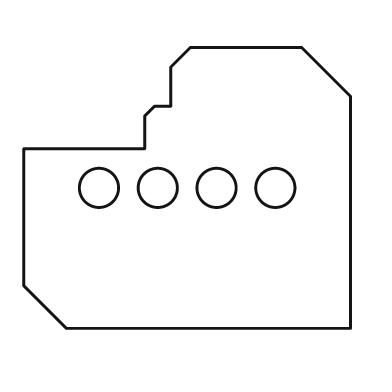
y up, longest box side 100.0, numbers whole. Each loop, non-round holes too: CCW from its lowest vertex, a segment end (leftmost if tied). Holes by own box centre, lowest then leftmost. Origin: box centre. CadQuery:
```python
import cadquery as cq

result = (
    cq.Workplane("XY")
    .moveTo(-37.0, -43.0)
    .lineTo(50.0, -43.0)
    .lineTo(50.0, 28.0)
    .lineTo(35.0, 43.0)
    .lineTo(1.0, 43.0)
    .lineTo(-5.0, 37.0)
    .lineTo(-5.0, 25.0)
    .lineTo(-10.0, 25.0)
    .lineTo(-13.0, 22.0)
    .lineTo(-13.0, 12.0)
    .lineTo(-50.0, 12.0)
    .lineTo(-50.0, -30.0)
    .close()
    .moveTo(-27.0, 0.0)
    .circle(6.0)
    .moveTo(-9.0, 0.0)
    .circle(6.0)
    .moveTo(9.0, 0.0)
    .circle(6.0)
    .moveTo(27.0, 0.0)
    .circle(6.0)
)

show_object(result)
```